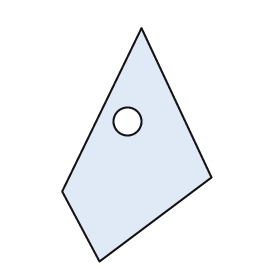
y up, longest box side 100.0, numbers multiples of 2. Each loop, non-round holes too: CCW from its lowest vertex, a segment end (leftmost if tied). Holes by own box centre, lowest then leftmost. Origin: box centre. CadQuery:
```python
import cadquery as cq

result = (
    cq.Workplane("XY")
    .moveTo(-16.0, -50.0)
    .lineTo(32.0, -14.0)
    .lineTo(2.0, 50.0)
    .lineTo(-32.0, -20.0)
    .close()
    .moveTo(-4.0, 10.0)
    .circle(6.0)
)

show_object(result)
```